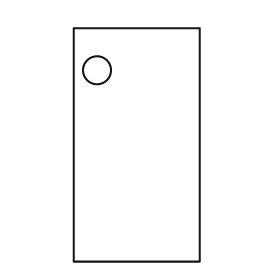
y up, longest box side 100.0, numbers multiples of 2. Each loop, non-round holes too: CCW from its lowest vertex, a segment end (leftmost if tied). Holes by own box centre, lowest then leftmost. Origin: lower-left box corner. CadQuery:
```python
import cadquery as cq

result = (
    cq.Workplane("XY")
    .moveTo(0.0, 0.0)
    .lineTo(54.0, 0.0)
    .lineTo(54.0, 100.0)
    .lineTo(0.0, 100.0)
    .close()
    .moveTo(10.0, 82.0)
    .circle(6.0)
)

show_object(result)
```